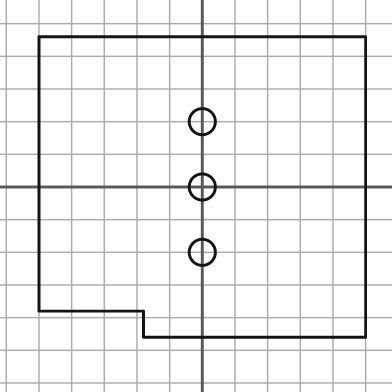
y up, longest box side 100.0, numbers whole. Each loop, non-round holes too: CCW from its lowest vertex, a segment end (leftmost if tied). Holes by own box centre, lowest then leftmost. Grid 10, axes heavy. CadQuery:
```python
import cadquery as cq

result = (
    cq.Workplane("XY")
    .moveTo(-18.0, -46.0)
    .lineTo(50.0, -46.0)
    .lineTo(50.0, 46.0)
    .lineTo(-50.0, 46.0)
    .lineTo(-50.0, -38.0)
    .lineTo(-18.0, -38.0)
    .close()
    .moveTo(0.0, -20.0)
    .circle(4.0)
    .moveTo(0.0, 0.0)
    .circle(4.0)
    .moveTo(0.0, 20.0)
    .circle(4.0)
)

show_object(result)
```